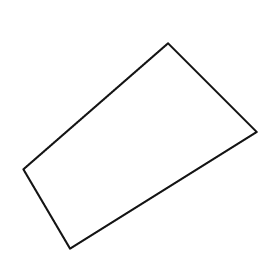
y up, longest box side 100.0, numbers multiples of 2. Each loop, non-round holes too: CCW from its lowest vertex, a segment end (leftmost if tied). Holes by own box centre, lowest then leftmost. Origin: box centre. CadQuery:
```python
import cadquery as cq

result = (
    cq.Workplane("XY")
    .moveTo(-30.0, -44.0)
    .lineTo(50.0, 6.0)
    .lineTo(12.0, 44.0)
    .lineTo(-50.0, -10.0)
    .close()
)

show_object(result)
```